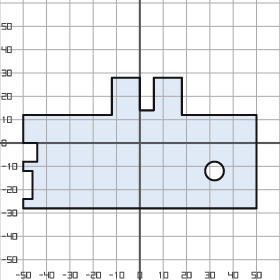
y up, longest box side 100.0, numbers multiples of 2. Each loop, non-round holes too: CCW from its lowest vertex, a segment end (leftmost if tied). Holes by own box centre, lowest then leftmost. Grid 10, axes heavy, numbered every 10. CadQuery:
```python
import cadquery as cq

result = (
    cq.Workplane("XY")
    .moveTo(-50.0, -28.0)
    .lineTo(50.0, -28.0)
    .lineTo(50.0, 12.0)
    .lineTo(18.0, 12.0)
    .lineTo(18.0, 28.0)
    .lineTo(6.0, 28.0)
    .lineTo(6.0, 14.0)
    .lineTo(0.0, 14.0)
    .lineTo(0.0, 28.0)
    .lineTo(-12.0, 28.0)
    .lineTo(-12.0, 12.0)
    .lineTo(-50.0, 12.0)
    .lineTo(-50.0, 0.0)
    .lineTo(-44.0, 0.0)
    .lineTo(-44.0, -8.0)
    .lineTo(-50.0, -8.0)
    .lineTo(-50.0, -12.0)
    .lineTo(-46.0, -12.0)
    .lineTo(-46.0, -24.0)
    .lineTo(-50.0, -24.0)
    .close()
    .moveTo(32.0, -12.0)
    .circle(4.0)
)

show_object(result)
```